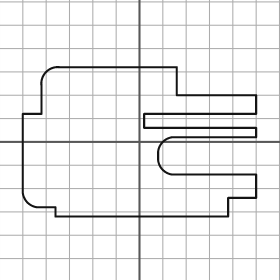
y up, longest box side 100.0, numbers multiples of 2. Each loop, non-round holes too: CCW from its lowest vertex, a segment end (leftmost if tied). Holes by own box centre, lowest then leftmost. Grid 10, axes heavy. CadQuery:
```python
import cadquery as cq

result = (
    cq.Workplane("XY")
    .moveTo(-36.0, -32.0)
    .lineTo(38.0, -32.0)
    .lineTo(38.0, -24.0)
    .lineTo(50.0, -24.0)
    .lineTo(50.0, -14.0)
    .lineTo(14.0, -14.0)
    .threePointArc((10.0, -12.0), (8.0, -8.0))
    .lineTo(8.0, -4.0)
    .threePointArc((10.0, 0.0), (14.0, 2.0))
    .lineTo(50.0, 2.0)
    .lineTo(50.0, 6.0)
    .lineTo(2.0, 6.0)
    .lineTo(2.0, 12.0)
    .lineTo(50.0, 12.0)
    .lineTo(50.0, 20.0)
    .lineTo(16.0, 20.0)
    .lineTo(16.0, 32.0)
    .lineTo(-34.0, 32.0)
    .threePointArc((-40.0, 30.0), (-42.0, 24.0))
    .lineTo(-42.0, 12.0)
    .lineTo(-50.0, 12.0)
    .lineTo(-50.0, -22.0)
    .threePointArc((-48.0, -26.0), (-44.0, -28.0))
    .lineTo(-36.0, -28.0)
    .close()
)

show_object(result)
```